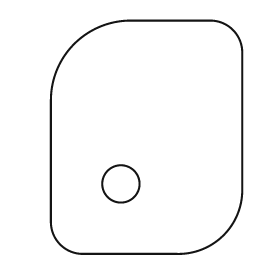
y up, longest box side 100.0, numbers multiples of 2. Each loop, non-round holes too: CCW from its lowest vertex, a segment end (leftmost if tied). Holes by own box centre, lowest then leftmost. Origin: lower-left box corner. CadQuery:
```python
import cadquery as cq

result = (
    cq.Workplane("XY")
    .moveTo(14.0, 0.0)
    .lineTo(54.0, 0.0)
    .threePointArc((74.0, 8.0), (82.0, 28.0))
    .lineTo(82.0, 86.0)
    .threePointArc((78.0, 96.0), (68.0, 100.0))
    .lineTo(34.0, 100.0)
    .threePointArc((10.0, 90.0), (0.0, 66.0))
    .lineTo(0.0, 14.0)
    .threePointArc((4.0, 4.0), (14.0, 0.0))
    .close()
    .moveTo(30.0, 30.0)
    .circle(8.0)
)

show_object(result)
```